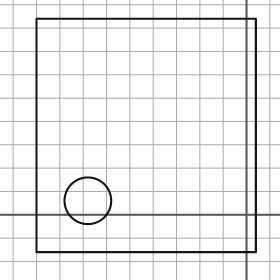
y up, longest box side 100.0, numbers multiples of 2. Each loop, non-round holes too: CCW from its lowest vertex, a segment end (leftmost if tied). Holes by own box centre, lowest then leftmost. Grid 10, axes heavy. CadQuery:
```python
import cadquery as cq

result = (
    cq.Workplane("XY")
    .moveTo(-90.0, -16.0)
    .lineTo(4.0, -16.0)
    .lineTo(4.0, 84.0)
    .lineTo(-90.0, 84.0)
    .close()
    .moveTo(-68.0, 6.0)
    .circle(10.0)
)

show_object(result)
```